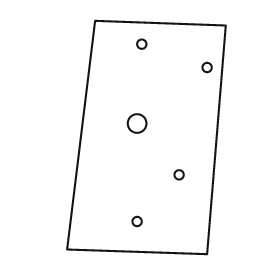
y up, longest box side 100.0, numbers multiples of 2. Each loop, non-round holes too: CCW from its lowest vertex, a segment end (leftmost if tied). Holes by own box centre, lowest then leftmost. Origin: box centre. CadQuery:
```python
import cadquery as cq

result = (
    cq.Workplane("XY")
    .moveTo(26.0, -50.0)
    .lineTo(34.0, 48.0)
    .lineTo(-22.0, 50.0)
    .lineTo(-34.0, -48.0)
    .close()
    .moveTo(-4.0, -36.0)
    .circle(2.0)
    .moveTo(14.0, -16.0)
    .circle(2.0)
    .moveTo(-4.0, 6.0)
    .circle(4.0)
    .moveTo(26.0, 30.0)
    .circle(2.0)
    .moveTo(-2.0, 40.0)
    .circle(2.0)
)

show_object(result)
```